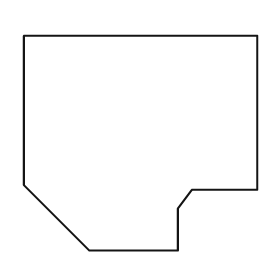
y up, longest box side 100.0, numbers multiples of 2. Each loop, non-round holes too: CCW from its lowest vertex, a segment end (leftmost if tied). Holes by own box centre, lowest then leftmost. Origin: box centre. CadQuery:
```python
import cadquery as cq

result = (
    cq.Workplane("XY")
    .moveTo(-22.0, -46.0)
    .lineTo(16.0, -46.0)
    .lineTo(16.0, -28.0)
    .lineTo(22.0, -20.0)
    .lineTo(50.0, -20.0)
    .lineTo(50.0, 46.0)
    .lineTo(-50.0, 46.0)
    .lineTo(-50.0, -18.0)
    .close()
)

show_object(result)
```